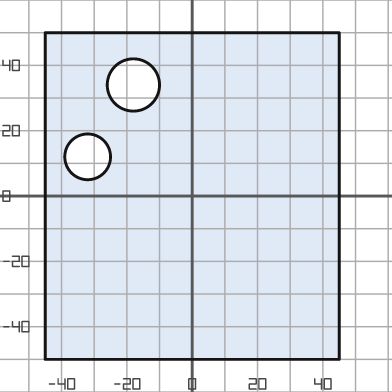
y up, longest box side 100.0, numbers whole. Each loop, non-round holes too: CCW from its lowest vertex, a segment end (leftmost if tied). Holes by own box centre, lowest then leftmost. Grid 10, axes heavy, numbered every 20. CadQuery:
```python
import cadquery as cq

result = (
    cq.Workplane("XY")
    .moveTo(-45.0, -50.0)
    .lineTo(45.0, -50.0)
    .lineTo(45.0, 50.0)
    .lineTo(-45.0, 50.0)
    .close()
    .moveTo(-32.0, 12.0)
    .circle(7.0)
    .moveTo(-18.0, 34.0)
    .circle(8.0)
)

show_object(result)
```